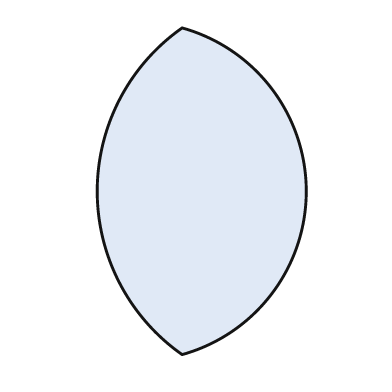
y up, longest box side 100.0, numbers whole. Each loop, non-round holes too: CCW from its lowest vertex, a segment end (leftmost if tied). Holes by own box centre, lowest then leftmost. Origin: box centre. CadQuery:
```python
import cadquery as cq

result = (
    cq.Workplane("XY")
    .moveTo(-6.0, -50.0)
    .threePointArc((32.0, 0.0), (-6.0, 50.0))
    .threePointArc((-32.0, 0.0), (-6.0, -50.0))
    .close()
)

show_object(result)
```